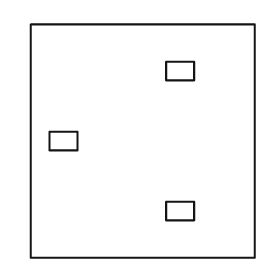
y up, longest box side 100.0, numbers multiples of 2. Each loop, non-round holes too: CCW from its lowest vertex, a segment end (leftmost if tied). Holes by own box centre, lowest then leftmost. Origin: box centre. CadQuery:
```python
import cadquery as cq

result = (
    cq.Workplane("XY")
    .moveTo(-48.0, -50.0)
    .lineTo(48.0, -50.0)
    .lineTo(48.0, 50.0)
    .lineTo(-48.0, 50.0)
    .close()
    .moveTo(10.0, -34.0)
    .lineTo(22.0, -34.0)
    .lineTo(22.0, -26.0)
    .lineTo(10.0, -26.0)
    .close()
    .moveTo(-40.0, -4.0)
    .lineTo(-28.0, -4.0)
    .lineTo(-28.0, 4.0)
    .lineTo(-40.0, 4.0)
    .close()
    .moveTo(10.0, 26.0)
    .lineTo(22.0, 26.0)
    .lineTo(22.0, 34.0)
    .lineTo(10.0, 34.0)
    .close()
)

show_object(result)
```